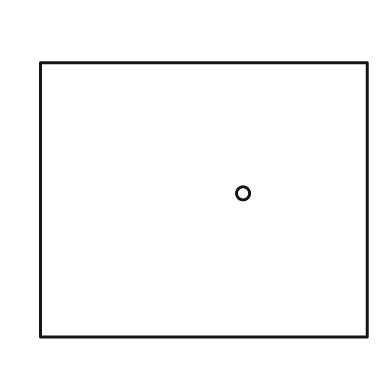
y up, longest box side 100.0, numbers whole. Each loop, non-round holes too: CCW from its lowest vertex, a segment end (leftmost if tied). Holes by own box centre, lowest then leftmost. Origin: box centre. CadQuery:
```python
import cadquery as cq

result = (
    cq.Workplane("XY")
    .moveTo(-50.0, -42.0)
    .lineTo(50.0, -42.0)
    .lineTo(50.0, 42.0)
    .lineTo(-50.0, 42.0)
    .close()
    .moveTo(12.0, 2.0)
    .circle(2.0)
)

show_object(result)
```